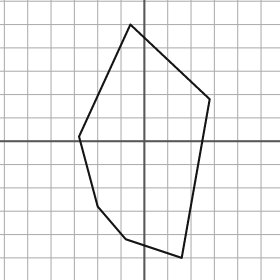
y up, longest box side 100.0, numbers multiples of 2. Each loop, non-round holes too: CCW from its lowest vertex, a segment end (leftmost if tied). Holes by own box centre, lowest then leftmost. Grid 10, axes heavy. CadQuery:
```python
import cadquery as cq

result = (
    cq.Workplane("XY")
    .moveTo(16.0, -50.0)
    .lineTo(28.0, 18.0)
    .lineTo(-6.0, 50.0)
    .lineTo(-28.0, 2.0)
    .lineTo(-20.0, -28.0)
    .lineTo(-8.0, -42.0)
    .close()
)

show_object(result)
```